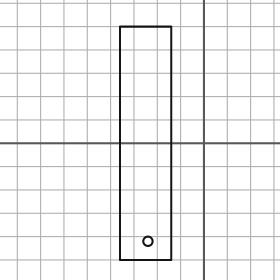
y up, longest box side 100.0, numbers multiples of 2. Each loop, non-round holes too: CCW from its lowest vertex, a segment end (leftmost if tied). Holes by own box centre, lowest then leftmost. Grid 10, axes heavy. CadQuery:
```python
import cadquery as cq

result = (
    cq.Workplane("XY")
    .moveTo(-36.0, -50.0)
    .lineTo(-14.0, -50.0)
    .lineTo(-14.0, 50.0)
    .lineTo(-36.0, 50.0)
    .close()
    .moveTo(-24.0, -42.0)
    .circle(2.0)
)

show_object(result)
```